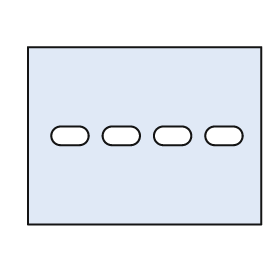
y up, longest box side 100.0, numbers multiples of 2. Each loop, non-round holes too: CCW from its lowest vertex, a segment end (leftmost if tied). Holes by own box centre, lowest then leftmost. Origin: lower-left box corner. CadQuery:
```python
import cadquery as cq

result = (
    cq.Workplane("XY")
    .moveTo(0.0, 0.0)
    .lineTo(100.0, 0.0)
    .lineTo(100.0, 76.0)
    .lineTo(0.0, 76.0)
    .close()
    .moveTo(14.0, 34.0)
    .lineTo(22.0, 34.0)
    .threePointArc((26.0, 38.0), (22.0, 42.0))
    .lineTo(14.0, 42.0)
    .threePointArc((10.0, 38.0), (14.0, 34.0))
    .close()
    .moveTo(36.0, 34.0)
    .lineTo(44.0, 34.0)
    .threePointArc((48.0, 38.0), (44.0, 42.0))
    .lineTo(36.0, 42.0)
    .threePointArc((32.0, 38.0), (36.0, 34.0))
    .close()
    .moveTo(58.0, 34.0)
    .lineTo(66.0, 34.0)
    .threePointArc((70.0, 38.0), (66.0, 42.0))
    .lineTo(58.0, 42.0)
    .threePointArc((54.0, 38.0), (58.0, 34.0))
    .close()
    .moveTo(80.0, 34.0)
    .lineTo(88.0, 34.0)
    .threePointArc((92.0, 38.0), (88.0, 42.0))
    .lineTo(80.0, 42.0)
    .threePointArc((76.0, 38.0), (80.0, 34.0))
    .close()
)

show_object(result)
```